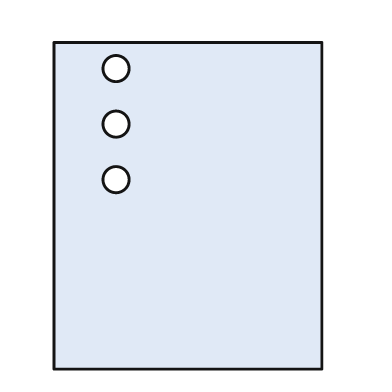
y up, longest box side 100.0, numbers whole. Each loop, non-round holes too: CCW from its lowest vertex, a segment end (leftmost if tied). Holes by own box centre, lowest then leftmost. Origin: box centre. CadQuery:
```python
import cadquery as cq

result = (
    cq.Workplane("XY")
    .moveTo(-41.0, -50.0)
    .lineTo(41.0, -50.0)
    .lineTo(41.0, 50.0)
    .lineTo(-41.0, 50.0)
    .close()
    .moveTo(-22.0, 8.0)
    .circle(4.0)
    .moveTo(-22.0, 25.0)
    .circle(4.0)
    .moveTo(-22.0, 42.0)
    .circle(4.0)
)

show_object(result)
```